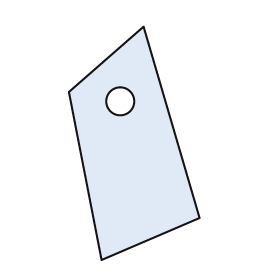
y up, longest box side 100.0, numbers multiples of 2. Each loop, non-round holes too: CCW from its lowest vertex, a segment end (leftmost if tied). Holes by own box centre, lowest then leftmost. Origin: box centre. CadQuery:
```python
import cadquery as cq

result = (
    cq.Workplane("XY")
    .moveTo(-14.0, -50.0)
    .lineTo(28.0, -32.0)
    .lineTo(4.0, 50.0)
    .lineTo(-28.0, 22.0)
    .close()
    .moveTo(-6.0, 18.0)
    .circle(6.0)
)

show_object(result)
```